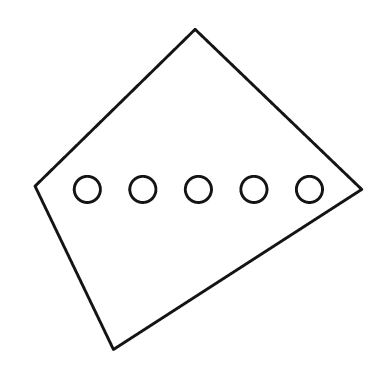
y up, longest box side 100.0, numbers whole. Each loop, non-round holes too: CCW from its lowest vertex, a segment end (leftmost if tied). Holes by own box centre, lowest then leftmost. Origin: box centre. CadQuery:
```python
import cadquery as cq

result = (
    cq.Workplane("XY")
    .moveTo(-26.0, -49.0)
    .lineTo(50.0, 0.0)
    .lineTo(-1.0, 49.0)
    .lineTo(-50.0, 1.0)
    .close()
    .moveTo(-34.0, 0.0)
    .circle(4.0)
    .moveTo(-17.0, 0.0)
    .circle(4.0)
    .moveTo(0.0, 0.0)
    .circle(4.0)
    .moveTo(17.0, 0.0)
    .circle(4.0)
    .moveTo(34.0, 0.0)
    .circle(4.0)
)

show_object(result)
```